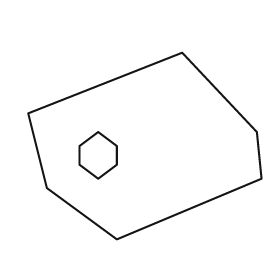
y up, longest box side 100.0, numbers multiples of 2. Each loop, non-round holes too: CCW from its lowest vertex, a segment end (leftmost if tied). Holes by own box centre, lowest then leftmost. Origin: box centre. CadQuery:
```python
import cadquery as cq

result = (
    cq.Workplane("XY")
    .moveTo(-12.0, -40.0)
    .lineTo(50.0, -14.0)
    .lineTo(48.0, 6.0)
    .lineTo(16.0, 40.0)
    .lineTo(-50.0, 14.0)
    .lineTo(-42.0, -18.0)
    .close()
    .moveTo(-20.0, -14.0)
    .lineTo(-12.0, -8.0)
    .lineTo(-12.0, 0.0)
    .lineTo(-20.0, 6.0)
    .lineTo(-28.0, 0.0)
    .lineTo(-28.0, -8.0)
    .close()
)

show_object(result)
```